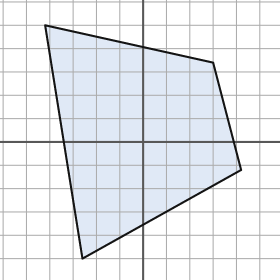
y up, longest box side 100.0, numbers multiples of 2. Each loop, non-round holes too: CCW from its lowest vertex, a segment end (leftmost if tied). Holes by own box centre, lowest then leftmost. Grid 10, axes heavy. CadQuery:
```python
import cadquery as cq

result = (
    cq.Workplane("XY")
    .moveTo(-26.0, -50.0)
    .lineTo(42.0, -12.0)
    .lineTo(30.0, 34.0)
    .lineTo(-42.0, 50.0)
    .close()
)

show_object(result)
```